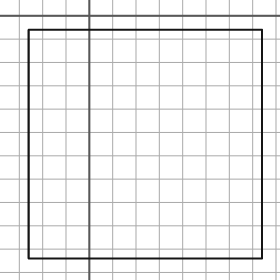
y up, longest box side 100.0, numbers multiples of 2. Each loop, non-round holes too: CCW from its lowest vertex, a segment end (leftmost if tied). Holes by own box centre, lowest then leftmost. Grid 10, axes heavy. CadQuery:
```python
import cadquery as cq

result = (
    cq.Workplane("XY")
    .moveTo(-26.0, -104.0)
    .lineTo(74.0, -104.0)
    .lineTo(74.0, -6.0)
    .lineTo(-26.0, -6.0)
    .close()
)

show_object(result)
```